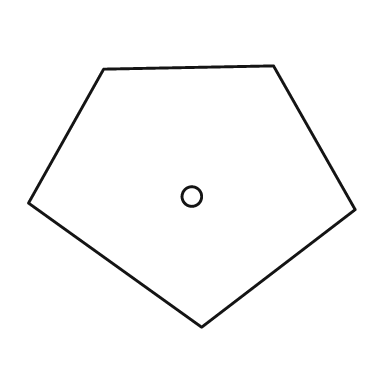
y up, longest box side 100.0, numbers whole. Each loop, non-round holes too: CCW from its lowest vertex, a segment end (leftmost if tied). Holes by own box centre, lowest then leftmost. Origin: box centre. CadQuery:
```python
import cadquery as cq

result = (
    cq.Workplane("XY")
    .moveTo(3.0, -40.0)
    .lineTo(50.0, -4.0)
    .lineTo(25.0, 40.0)
    .lineTo(-27.0, 39.0)
    .lineTo(-50.0, -2.0)
    .close()
    .moveTo(0.0, 0.0)
    .circle(3.0)
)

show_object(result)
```